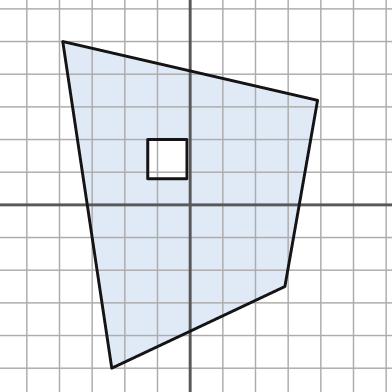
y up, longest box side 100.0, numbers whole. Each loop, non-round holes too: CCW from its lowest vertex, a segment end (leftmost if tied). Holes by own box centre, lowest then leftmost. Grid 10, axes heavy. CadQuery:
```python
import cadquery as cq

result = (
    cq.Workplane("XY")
    .moveTo(-24.0, -50.0)
    .lineTo(29.0, -25.0)
    .lineTo(39.0, 32.0)
    .lineTo(-39.0, 50.0)
    .close()
    .moveTo(-13.0, 8.0)
    .lineTo(-1.0, 8.0)
    .lineTo(-1.0, 20.0)
    .lineTo(-13.0, 20.0)
    .close()
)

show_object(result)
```